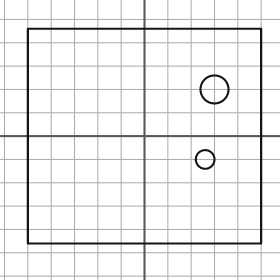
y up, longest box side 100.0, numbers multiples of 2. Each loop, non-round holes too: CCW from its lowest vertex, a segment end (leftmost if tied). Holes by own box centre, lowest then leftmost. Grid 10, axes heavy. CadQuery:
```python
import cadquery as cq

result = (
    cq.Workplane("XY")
    .moveTo(-50.0, -46.0)
    .lineTo(50.0, -46.0)
    .lineTo(50.0, 46.0)
    .lineTo(-50.0, 46.0)
    .close()
    .moveTo(26.0, -10.0)
    .circle(4.0)
    .moveTo(30.0, 20.0)
    .circle(6.0)
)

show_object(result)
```